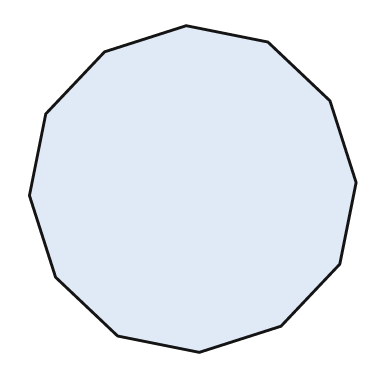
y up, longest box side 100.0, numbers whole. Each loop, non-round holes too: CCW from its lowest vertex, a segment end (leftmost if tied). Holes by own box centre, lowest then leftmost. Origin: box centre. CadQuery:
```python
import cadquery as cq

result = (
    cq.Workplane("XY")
    .moveTo(2.0, -50.0)
    .lineTo(27.0, -42.0)
    .lineTo(45.0, -23.0)
    .lineTo(50.0, 2.0)
    .lineTo(42.0, 27.0)
    .lineTo(23.0, 45.0)
    .lineTo(-2.0, 50.0)
    .lineTo(-27.0, 42.0)
    .lineTo(-45.0, 23.0)
    .lineTo(-50.0, -2.0)
    .lineTo(-42.0, -27.0)
    .lineTo(-23.0, -45.0)
    .close()
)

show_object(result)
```